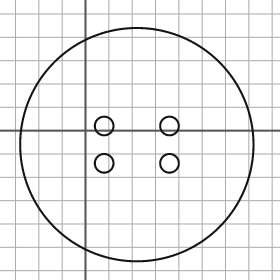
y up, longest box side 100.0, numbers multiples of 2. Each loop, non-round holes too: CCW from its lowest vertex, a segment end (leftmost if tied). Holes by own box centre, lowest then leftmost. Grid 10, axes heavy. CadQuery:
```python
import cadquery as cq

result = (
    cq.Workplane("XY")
    .moveTo(22.0, -6.0)
    .circle(50.0)
    .moveTo(8.0, -14.0)
    .circle(4.0)
    .moveTo(36.0, -14.0)
    .circle(4.0)
    .moveTo(8.0, 2.0)
    .circle(4.0)
    .moveTo(36.0, 2.0)
    .circle(4.0)
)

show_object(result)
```